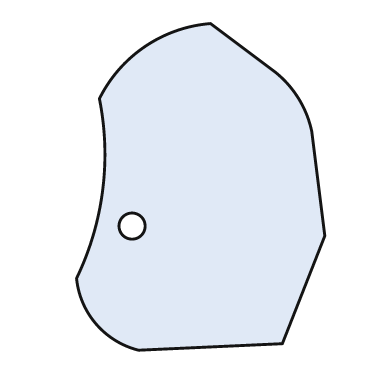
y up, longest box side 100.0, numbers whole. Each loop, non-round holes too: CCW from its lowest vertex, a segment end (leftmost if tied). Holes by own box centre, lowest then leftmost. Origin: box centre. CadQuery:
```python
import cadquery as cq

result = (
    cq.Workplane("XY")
    .moveTo(-19.0, -50.0)
    .lineTo(25.0, -48.0)
    .lineTo(38.0, -15.0)
    .lineTo(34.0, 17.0)
    .threePointArc((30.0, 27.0), (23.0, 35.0))
    .lineTo(3.0, 50.0)
    .threePointArc((-17.0, 43.0), (-31.0, 27.0))
    .threePointArc((-30.0, -1.0), (-38.0, -28.0))
    .threePointArc((-32.0, -42.0), (-19.0, -50.0))
    .close()
    .moveTo(-21.0, -12.0)
    .circle(4.0)
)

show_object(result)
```